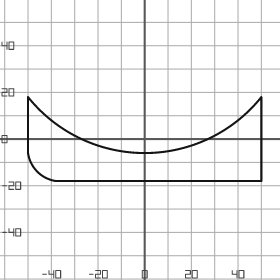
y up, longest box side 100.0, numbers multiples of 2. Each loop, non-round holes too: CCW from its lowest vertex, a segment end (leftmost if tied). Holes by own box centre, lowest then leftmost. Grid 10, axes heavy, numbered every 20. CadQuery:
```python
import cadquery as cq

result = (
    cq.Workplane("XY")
    .moveTo(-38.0, -18.0)
    .lineTo(50.0, -18.0)
    .lineTo(50.0, 18.0)
    .threePointArc((0.0, -6.0), (-50.0, 18.0))
    .lineTo(-50.0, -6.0)
    .threePointArc((-46.0, -14.0), (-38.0, -18.0))
    .close()
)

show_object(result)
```